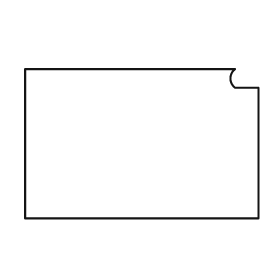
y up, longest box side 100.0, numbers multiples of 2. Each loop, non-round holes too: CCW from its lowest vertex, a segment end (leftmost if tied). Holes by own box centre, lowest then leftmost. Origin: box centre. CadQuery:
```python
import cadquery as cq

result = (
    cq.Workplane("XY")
    .moveTo(-50.0, -32.0)
    .lineTo(50.0, -32.0)
    .lineTo(50.0, 24.0)
    .lineTo(40.0, 24.0)
    .threePointArc((38.0, 28.0), (40.0, 32.0))
    .lineTo(-50.0, 32.0)
    .close()
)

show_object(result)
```